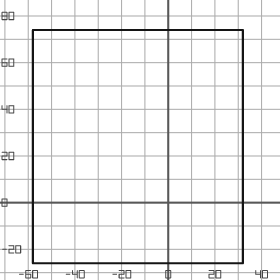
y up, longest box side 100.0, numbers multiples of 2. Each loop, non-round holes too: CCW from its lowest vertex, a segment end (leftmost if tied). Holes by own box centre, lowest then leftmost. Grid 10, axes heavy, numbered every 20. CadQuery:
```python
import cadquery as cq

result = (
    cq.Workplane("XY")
    .moveTo(-58.0, -26.0)
    .lineTo(32.0, -26.0)
    .lineTo(32.0, 74.0)
    .lineTo(-58.0, 74.0)
    .close()
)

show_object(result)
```